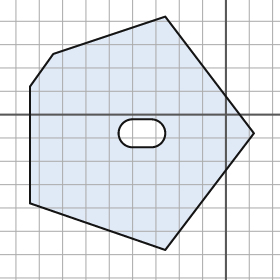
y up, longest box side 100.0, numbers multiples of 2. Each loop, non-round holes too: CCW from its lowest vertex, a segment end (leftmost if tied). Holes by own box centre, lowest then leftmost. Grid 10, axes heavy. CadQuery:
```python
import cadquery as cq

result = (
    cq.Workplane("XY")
    .moveTo(-26.0, -58.0)
    .lineTo(12.0, -8.0)
    .lineTo(-26.0, 42.0)
    .lineTo(-74.0, 26.0)
    .lineTo(-84.0, 12.0)
    .lineTo(-84.0, -38.0)
    .close()
    .moveTo(-40.0, -14.0)
    .lineTo(-32.0, -14.0)
    .threePointArc((-26.0, -8.0), (-32.0, -2.0))
    .lineTo(-40.0, -2.0)
    .threePointArc((-46.0, -8.0), (-40.0, -14.0))
    .close()
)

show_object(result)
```